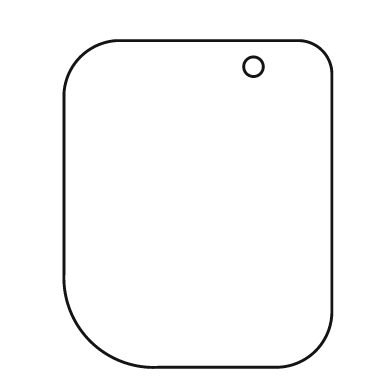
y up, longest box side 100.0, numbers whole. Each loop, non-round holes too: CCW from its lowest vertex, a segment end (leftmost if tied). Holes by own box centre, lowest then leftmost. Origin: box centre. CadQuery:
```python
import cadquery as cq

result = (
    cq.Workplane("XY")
    .moveTo(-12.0, -50.0)
    .lineTo(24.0, -50.0)
    .threePointArc((36.0, -45.0), (41.0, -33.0))
    .lineTo(41.0, 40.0)
    .threePointArc((38.0, 47.0), (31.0, 50.0))
    .lineTo(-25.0, 50.0)
    .threePointArc((-36.0, 45.0), (-41.0, 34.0))
    .lineTo(-41.0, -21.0)
    .threePointArc((-33.0, -42.0), (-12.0, -50.0))
    .close()
    .moveTo(17.0, 42.0)
    .circle(3.0)
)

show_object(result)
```